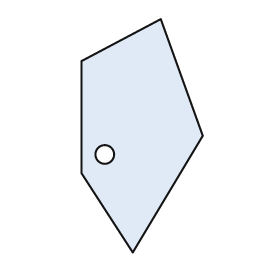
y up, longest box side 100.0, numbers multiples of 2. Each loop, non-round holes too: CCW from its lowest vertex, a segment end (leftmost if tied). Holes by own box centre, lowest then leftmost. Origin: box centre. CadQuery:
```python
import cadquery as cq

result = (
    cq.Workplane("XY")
    .moveTo(-4.0, -50.0)
    .lineTo(26.0, 0.0)
    .lineTo(8.0, 50.0)
    .lineTo(-26.0, 32.0)
    .lineTo(-26.0, -16.0)
    .close()
    .moveTo(-16.0, -8.0)
    .circle(4.0)
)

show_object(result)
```